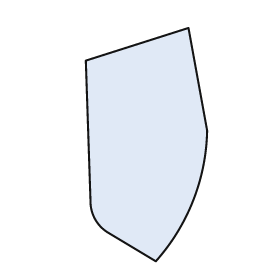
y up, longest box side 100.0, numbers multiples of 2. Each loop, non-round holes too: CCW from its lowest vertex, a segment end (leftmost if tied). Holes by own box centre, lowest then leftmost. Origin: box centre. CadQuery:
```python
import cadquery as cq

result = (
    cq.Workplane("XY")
    .moveTo(4.0, -50.0)
    .threePointArc((20.0, -24.0), (26.0, 6.0))
    .lineTo(18.0, 50.0)
    .lineTo(-26.0, 36.0)
    .lineTo(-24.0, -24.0)
    .threePointArc((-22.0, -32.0), (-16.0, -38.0))
    .close()
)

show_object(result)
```